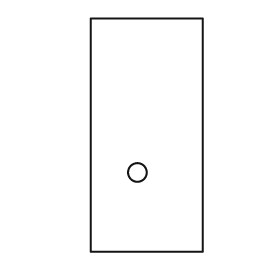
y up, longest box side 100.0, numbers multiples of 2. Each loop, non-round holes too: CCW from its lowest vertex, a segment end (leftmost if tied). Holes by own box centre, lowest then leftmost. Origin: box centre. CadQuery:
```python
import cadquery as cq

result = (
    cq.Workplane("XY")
    .moveTo(-24.0, -50.0)
    .lineTo(24.0, -50.0)
    .lineTo(24.0, 50.0)
    .lineTo(-24.0, 50.0)
    .close()
    .moveTo(-4.0, -16.0)
    .circle(4.0)
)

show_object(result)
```